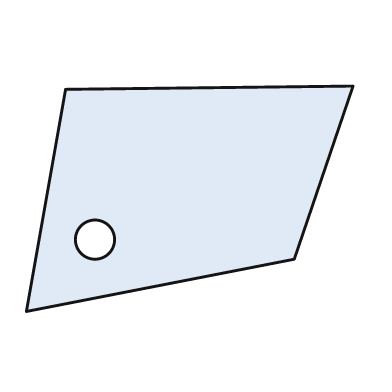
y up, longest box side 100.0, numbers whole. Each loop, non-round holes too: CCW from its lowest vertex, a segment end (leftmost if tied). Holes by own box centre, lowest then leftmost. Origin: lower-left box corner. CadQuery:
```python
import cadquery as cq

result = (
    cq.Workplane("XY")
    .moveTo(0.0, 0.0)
    .lineTo(82.0, 16.0)
    .lineTo(100.0, 69.0)
    .lineTo(12.0, 68.0)
    .close()
    .moveTo(21.0, 22.0)
    .circle(6.0)
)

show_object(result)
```